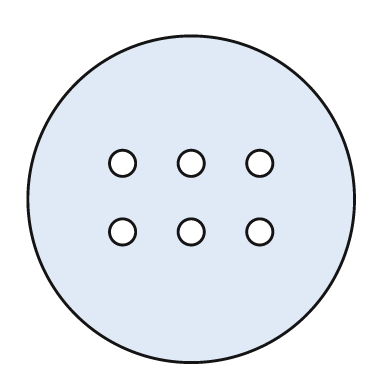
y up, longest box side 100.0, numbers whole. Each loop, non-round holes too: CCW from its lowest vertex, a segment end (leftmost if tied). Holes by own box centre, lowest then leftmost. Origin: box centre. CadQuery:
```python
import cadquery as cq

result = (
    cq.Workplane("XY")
    .moveTo(0.0, 0.0)
    .circle(50.0)
    .moveTo(-21.0, -10.0)
    .circle(4.0)
    .moveTo(0.0, -10.0)
    .circle(4.0)
    .moveTo(21.0, -10.0)
    .circle(4.0)
    .moveTo(-21.0, 11.0)
    .circle(4.0)
    .moveTo(0.0, 11.0)
    .circle(4.0)
    .moveTo(21.0, 11.0)
    .circle(4.0)
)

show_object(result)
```